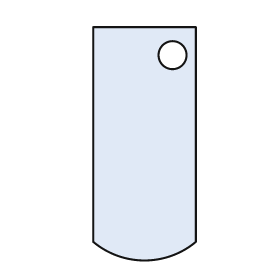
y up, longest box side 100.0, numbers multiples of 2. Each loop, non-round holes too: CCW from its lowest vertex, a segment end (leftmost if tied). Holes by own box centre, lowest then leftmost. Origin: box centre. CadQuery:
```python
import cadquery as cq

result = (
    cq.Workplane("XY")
    .moveTo(-22.0, -42.0)
    .threePointArc((0.0, -50.0), (22.0, -42.0))
    .lineTo(22.0, 50.0)
    .lineTo(-22.0, 50.0)
    .close()
    .moveTo(12.0, 38.0)
    .circle(6.0)
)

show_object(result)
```